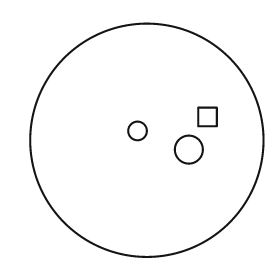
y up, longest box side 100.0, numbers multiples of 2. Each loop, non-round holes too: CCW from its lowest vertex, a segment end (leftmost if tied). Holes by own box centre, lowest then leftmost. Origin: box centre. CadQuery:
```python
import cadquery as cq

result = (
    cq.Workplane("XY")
    .moveTo(0.0, 0.0)
    .circle(50.0)
    .moveTo(18.0, -4.0)
    .circle(6.0)
    .moveTo(-4.0, 4.0)
    .circle(4.0)
    .moveTo(22.0, 6.0)
    .lineTo(30.0, 6.0)
    .lineTo(30.0, 14.0)
    .lineTo(22.0, 14.0)
    .close()
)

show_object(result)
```